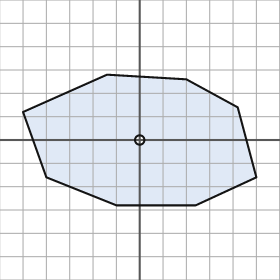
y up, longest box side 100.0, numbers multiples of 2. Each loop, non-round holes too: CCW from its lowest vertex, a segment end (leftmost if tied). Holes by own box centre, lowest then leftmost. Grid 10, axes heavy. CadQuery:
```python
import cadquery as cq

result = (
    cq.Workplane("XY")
    .moveTo(-10.0, -28.0)
    .lineTo(24.0, -28.0)
    .lineTo(50.0, -16.0)
    .lineTo(42.0, 14.0)
    .lineTo(20.0, 26.0)
    .lineTo(-14.0, 28.0)
    .lineTo(-50.0, 12.0)
    .lineTo(-40.0, -16.0)
    .close()
    .moveTo(0.0, 0.0)
    .circle(2.0)
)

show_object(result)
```